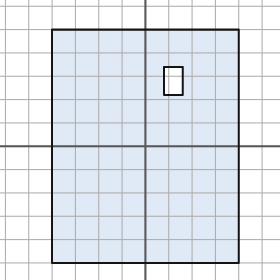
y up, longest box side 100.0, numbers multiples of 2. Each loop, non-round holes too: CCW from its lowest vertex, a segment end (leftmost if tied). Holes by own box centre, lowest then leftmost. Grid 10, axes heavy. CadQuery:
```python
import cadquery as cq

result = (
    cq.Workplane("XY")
    .moveTo(-40.0, -50.0)
    .lineTo(40.0, -50.0)
    .lineTo(40.0, 50.0)
    .lineTo(-40.0, 50.0)
    .close()
    .moveTo(8.0, 22.0)
    .lineTo(16.0, 22.0)
    .lineTo(16.0, 34.0)
    .lineTo(8.0, 34.0)
    .close()
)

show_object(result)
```